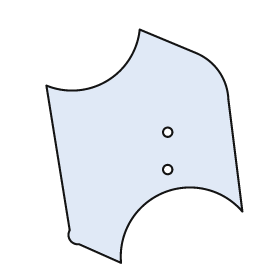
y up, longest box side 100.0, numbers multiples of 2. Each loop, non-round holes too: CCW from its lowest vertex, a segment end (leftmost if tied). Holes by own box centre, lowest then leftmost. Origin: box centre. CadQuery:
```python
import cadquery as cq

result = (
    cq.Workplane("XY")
    .moveTo(-10.0, -50.0)
    .threePointArc((8.0, -20.0), (42.0, -28.0))
    .lineTo(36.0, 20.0)
    .threePointArc((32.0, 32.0), (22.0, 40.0))
    .lineTo(-2.0, 50.0)
    .threePointArc((-16.0, 28.0), (-42.0, 26.0))
    .lineTo(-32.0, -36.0)
    .threePointArc((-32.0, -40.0), (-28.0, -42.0))
    .close()
    .moveTo(10.0, -10.0)
    .circle(2.0)
    .moveTo(10.0, 6.0)
    .circle(2.0)
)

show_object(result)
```